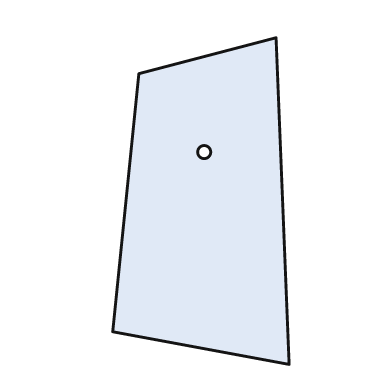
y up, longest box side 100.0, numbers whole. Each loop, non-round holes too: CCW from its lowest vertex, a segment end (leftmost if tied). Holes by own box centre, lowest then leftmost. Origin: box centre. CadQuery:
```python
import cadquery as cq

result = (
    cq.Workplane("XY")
    .moveTo(27.0, -50.0)
    .lineTo(23.0, 50.0)
    .lineTo(-19.0, 39.0)
    .lineTo(-27.0, -40.0)
    .close()
    .moveTo(1.0, 15.0)
    .circle(2.0)
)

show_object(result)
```